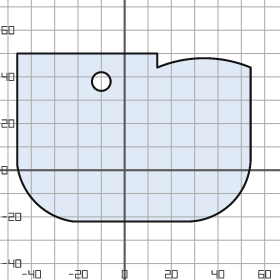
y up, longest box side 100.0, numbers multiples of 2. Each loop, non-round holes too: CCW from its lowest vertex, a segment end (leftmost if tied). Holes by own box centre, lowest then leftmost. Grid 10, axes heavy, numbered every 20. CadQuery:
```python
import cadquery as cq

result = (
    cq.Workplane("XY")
    .moveTo(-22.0, -22.0)
    .lineTo(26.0, -22.0)
    .threePointArc((46.0, -14.0), (54.0, 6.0))
    .lineTo(54.0, 44.0)
    .threePointArc((34.0, 48.0), (14.0, 44.0))
    .lineTo(14.0, 50.0)
    .lineTo(-46.0, 50.0)
    .lineTo(-46.0, 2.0)
    .threePointArc((-38.0, -14.0), (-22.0, -22.0))
    .close()
    .moveTo(-10.0, 38.0)
    .circle(4.0)
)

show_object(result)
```